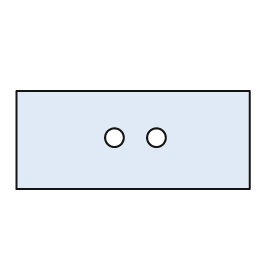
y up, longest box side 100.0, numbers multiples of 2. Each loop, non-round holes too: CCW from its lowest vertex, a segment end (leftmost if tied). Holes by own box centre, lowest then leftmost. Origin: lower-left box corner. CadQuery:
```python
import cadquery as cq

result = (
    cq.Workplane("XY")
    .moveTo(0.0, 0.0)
    .lineTo(100.0, 0.0)
    .lineTo(100.0, 42.0)
    .lineTo(0.0, 42.0)
    .close()
    .moveTo(42.0, 22.0)
    .circle(4.0)
    .moveTo(60.0, 22.0)
    .circle(4.0)
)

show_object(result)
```